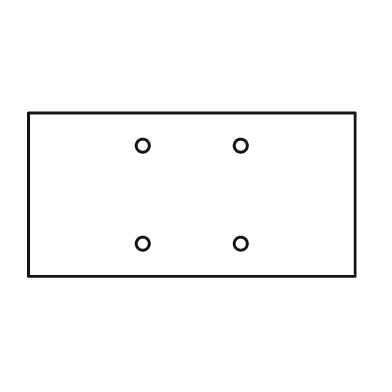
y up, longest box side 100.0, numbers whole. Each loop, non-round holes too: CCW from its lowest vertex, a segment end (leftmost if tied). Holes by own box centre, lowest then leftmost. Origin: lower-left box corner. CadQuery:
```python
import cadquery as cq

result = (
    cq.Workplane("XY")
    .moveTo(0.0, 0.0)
    .lineTo(100.0, 0.0)
    .lineTo(100.0, 50.0)
    .lineTo(0.0, 50.0)
    .close()
    .moveTo(35.0, 10.0)
    .circle(2.0)
    .moveTo(65.0, 10.0)
    .circle(2.0)
    .moveTo(35.0, 40.0)
    .circle(2.0)
    .moveTo(65.0, 40.0)
    .circle(2.0)
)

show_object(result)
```